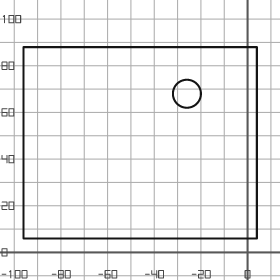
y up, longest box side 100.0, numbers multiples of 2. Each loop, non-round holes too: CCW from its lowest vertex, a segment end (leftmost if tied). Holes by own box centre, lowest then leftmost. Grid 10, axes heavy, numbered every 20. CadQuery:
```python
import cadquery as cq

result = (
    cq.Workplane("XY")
    .moveTo(-96.0, 6.0)
    .lineTo(4.0, 6.0)
    .lineTo(4.0, 88.0)
    .lineTo(-96.0, 88.0)
    .close()
    .moveTo(-26.0, 68.0)
    .circle(6.0)
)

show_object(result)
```